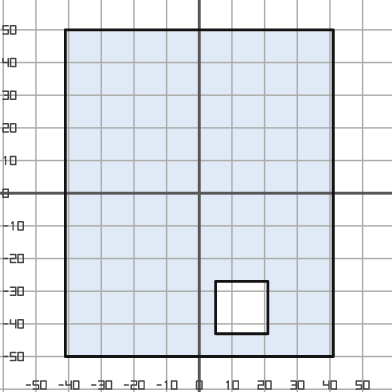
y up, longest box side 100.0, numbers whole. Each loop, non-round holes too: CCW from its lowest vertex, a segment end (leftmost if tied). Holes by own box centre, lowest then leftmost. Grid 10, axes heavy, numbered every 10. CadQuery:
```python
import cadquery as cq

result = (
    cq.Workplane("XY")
    .moveTo(-41.0, -50.0)
    .lineTo(41.0, -50.0)
    .lineTo(41.0, 50.0)
    .lineTo(-41.0, 50.0)
    .close()
    .moveTo(5.0, -43.0)
    .lineTo(21.0, -43.0)
    .lineTo(21.0, -27.0)
    .lineTo(5.0, -27.0)
    .close()
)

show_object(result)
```